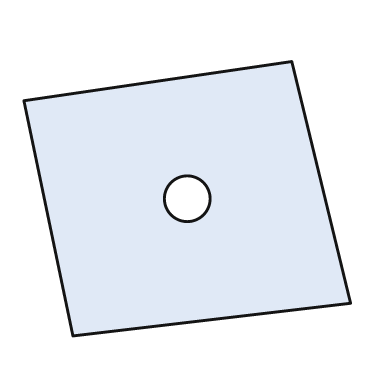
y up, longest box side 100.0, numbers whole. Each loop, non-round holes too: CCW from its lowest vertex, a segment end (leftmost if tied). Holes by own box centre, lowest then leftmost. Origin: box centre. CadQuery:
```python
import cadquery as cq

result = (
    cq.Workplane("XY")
    .moveTo(-35.0, -42.0)
    .lineTo(50.0, -32.0)
    .lineTo(32.0, 42.0)
    .lineTo(-50.0, 30.0)
    .close()
    .moveTo(0.0, 0.0)
    .circle(7.0)
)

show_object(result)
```